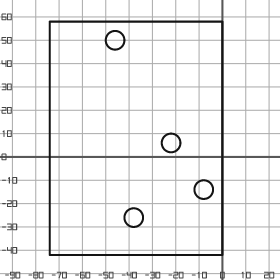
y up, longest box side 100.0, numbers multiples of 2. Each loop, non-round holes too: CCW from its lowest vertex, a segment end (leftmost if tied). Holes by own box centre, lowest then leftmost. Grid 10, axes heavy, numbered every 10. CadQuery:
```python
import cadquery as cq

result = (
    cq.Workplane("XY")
    .moveTo(-74.0, -42.0)
    .lineTo(0.0, -42.0)
    .lineTo(0.0, 58.0)
    .lineTo(-74.0, 58.0)
    .close()
    .moveTo(-38.0, -26.0)
    .circle(4.0)
    .moveTo(-8.0, -14.0)
    .circle(4.0)
    .moveTo(-22.0, 6.0)
    .circle(4.0)
    .moveTo(-46.0, 50.0)
    .circle(4.0)
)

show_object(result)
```